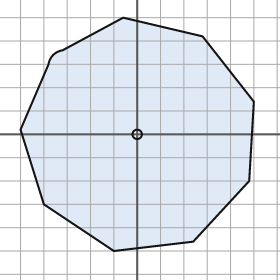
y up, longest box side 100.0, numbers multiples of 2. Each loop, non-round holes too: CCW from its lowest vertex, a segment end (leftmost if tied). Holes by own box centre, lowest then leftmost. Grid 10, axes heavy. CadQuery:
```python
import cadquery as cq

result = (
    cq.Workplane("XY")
    .moveTo(-10.0, -50.0)
    .lineTo(24.0, -46.0)
    .lineTo(48.0, -20.0)
    .lineTo(50.0, 14.0)
    .lineTo(28.0, 42.0)
    .lineTo(-6.0, 50.0)
    .lineTo(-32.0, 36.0)
    .threePointArc((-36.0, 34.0), (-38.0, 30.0))
    .lineTo(-50.0, 2.0)
    .lineTo(-40.0, -30.0)
    .close()
    .moveTo(0.0, 0.0)
    .circle(2.0)
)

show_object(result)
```